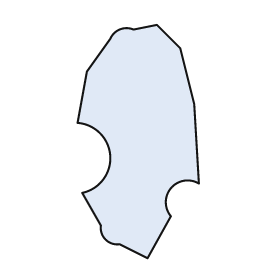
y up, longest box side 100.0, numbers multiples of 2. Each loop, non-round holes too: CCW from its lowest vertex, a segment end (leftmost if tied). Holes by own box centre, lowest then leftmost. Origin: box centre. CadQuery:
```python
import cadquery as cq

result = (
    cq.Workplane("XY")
    .moveTo(4.0, -50.0)
    .lineTo(14.0, -32.0)
    .threePointArc((14.0, -20.0), (26.0, -18.0))
    .lineTo(24.0, 16.0)
    .lineTo(18.0, 40.0)
    .lineTo(8.0, 50.0)
    .lineTo(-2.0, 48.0)
    .threePointArc((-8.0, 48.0), (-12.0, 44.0))
    .lineTo(-22.0, 30.0)
    .lineTo(-26.0, 8.0)
    .threePointArc((-12.0, -6.0), (-24.0, -22.0))
    .lineTo(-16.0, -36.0)
    .threePointArc((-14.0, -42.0), (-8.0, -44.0))
    .close()
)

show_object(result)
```